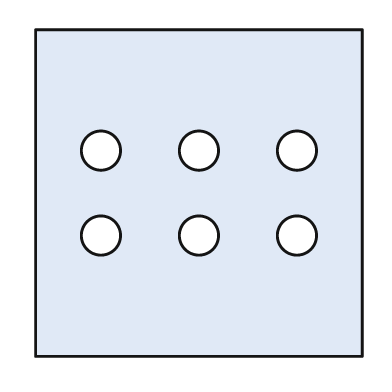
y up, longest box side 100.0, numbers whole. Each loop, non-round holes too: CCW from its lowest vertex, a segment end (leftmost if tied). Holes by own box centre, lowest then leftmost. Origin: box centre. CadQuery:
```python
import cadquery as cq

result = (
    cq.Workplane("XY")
    .moveTo(-50.0, -50.0)
    .lineTo(50.0, -50.0)
    .lineTo(50.0, 50.0)
    .lineTo(-50.0, 50.0)
    .close()
    .moveTo(-30.0, -13.0)
    .circle(6.0)
    .moveTo(0.0, -13.0)
    .circle(6.0)
    .moveTo(30.0, -13.0)
    .circle(6.0)
    .moveTo(-30.0, 13.0)
    .circle(6.0)
    .moveTo(0.0, 13.0)
    .circle(6.0)
    .moveTo(30.0, 13.0)
    .circle(6.0)
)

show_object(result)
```